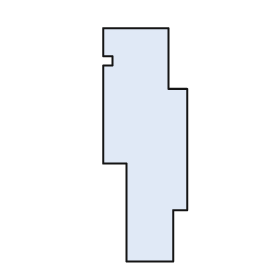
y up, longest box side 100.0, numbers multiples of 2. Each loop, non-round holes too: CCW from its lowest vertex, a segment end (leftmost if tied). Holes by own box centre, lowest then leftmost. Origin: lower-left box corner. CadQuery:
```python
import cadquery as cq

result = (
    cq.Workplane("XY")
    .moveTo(10.0, 0.0)
    .lineTo(30.0, 0.0)
    .lineTo(30.0, 22.0)
    .lineTo(36.0, 22.0)
    .lineTo(36.0, 74.0)
    .lineTo(28.0, 74.0)
    .lineTo(28.0, 100.0)
    .lineTo(0.0, 100.0)
    .lineTo(0.0, 88.0)
    .lineTo(4.0, 88.0)
    .lineTo(4.0, 84.0)
    .lineTo(0.0, 84.0)
    .lineTo(0.0, 42.0)
    .lineTo(10.0, 42.0)
    .close()
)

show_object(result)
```